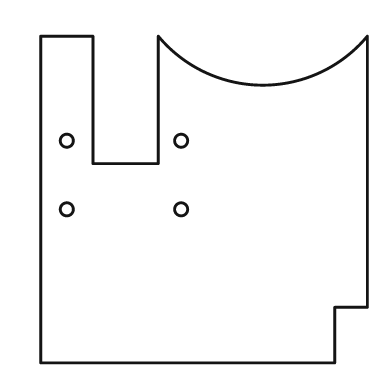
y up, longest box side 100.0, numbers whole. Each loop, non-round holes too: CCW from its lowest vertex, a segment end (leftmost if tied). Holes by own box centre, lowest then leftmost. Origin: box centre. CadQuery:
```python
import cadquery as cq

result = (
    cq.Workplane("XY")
    .moveTo(-50.0, -50.0)
    .lineTo(40.0, -50.0)
    .lineTo(40.0, -33.0)
    .lineTo(50.0, -33.0)
    .lineTo(50.0, 50.0)
    .threePointArc((18.0, 35.0), (-14.0, 50.0))
    .lineTo(-14.0, 11.0)
    .lineTo(-34.0, 11.0)
    .lineTo(-34.0, 50.0)
    .lineTo(-50.0, 50.0)
    .close()
    .moveTo(-42.0, -3.0)
    .circle(2.0)
    .moveTo(-7.0, -3.0)
    .circle(2.0)
    .moveTo(-42.0, 18.0)
    .circle(2.0)
    .moveTo(-7.0, 18.0)
    .circle(2.0)
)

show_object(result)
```